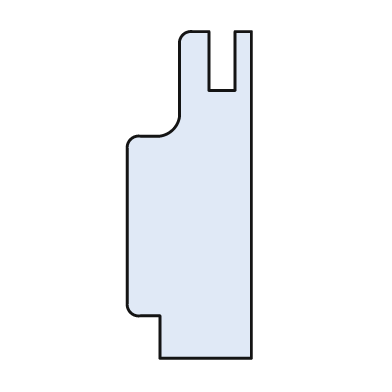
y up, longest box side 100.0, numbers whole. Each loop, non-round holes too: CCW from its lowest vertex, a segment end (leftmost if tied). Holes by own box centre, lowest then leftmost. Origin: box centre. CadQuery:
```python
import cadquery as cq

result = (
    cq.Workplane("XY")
    .moveTo(-9.0, -50.0)
    .lineTo(19.0, -50.0)
    .lineTo(19.0, 50.0)
    .lineTo(14.0, 50.0)
    .lineTo(14.0, 32.0)
    .lineTo(6.0, 32.0)
    .lineTo(6.0, 50.0)
    .lineTo(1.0, 50.0)
    .threePointArc((-2.0, 49.0), (-3.0, 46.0))
    .lineTo(-3.0, 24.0)
    .threePointArc((-5.0, 20.0), (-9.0, 18.0))
    .lineTo(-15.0, 18.0)
    .threePointArc((-18.0, 17.0), (-19.0, 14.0))
    .lineTo(-19.0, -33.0)
    .threePointArc((-18.0, -36.0), (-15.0, -37.0))
    .lineTo(-9.0, -37.0)
    .close()
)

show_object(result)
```